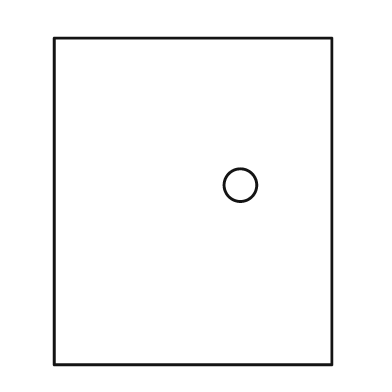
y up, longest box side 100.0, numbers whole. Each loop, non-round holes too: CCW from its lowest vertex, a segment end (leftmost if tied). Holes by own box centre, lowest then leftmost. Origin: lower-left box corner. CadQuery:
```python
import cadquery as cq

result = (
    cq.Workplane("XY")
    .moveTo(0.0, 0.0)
    .lineTo(85.0, 0.0)
    .lineTo(85.0, 100.0)
    .lineTo(0.0, 100.0)
    .close()
    .moveTo(57.0, 55.0)
    .circle(5.0)
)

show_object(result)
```